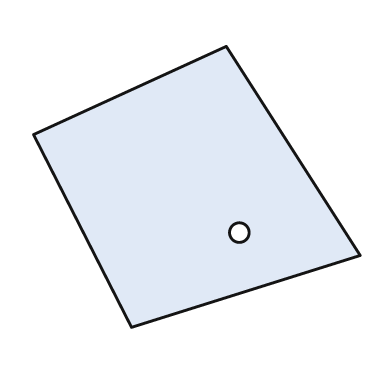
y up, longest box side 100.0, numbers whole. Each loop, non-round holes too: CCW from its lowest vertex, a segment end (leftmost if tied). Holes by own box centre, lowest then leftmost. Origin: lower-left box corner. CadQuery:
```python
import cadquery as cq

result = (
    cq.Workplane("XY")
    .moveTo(30.0, 0.0)
    .lineTo(100.0, 22.0)
    .lineTo(59.0, 86.0)
    .lineTo(0.0, 59.0)
    .close()
    .moveTo(63.0, 29.0)
    .circle(3.0)
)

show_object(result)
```